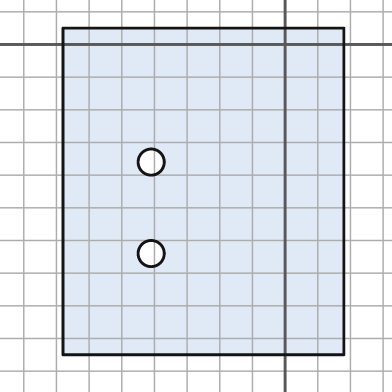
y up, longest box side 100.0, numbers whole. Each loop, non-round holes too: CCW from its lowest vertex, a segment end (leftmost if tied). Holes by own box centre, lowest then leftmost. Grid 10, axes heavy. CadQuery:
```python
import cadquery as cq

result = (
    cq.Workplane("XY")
    .moveTo(-68.0, -95.0)
    .lineTo(18.0, -95.0)
    .lineTo(18.0, 5.0)
    .lineTo(-68.0, 5.0)
    .close()
    .moveTo(-41.0, -64.0)
    .circle(4.0)
    .moveTo(-41.0, -36.0)
    .circle(4.0)
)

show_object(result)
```